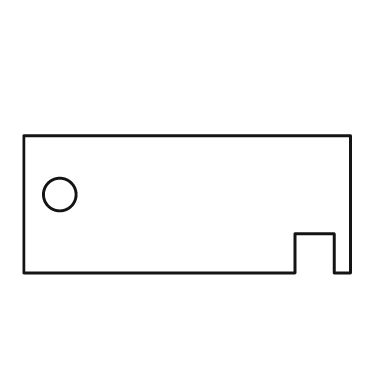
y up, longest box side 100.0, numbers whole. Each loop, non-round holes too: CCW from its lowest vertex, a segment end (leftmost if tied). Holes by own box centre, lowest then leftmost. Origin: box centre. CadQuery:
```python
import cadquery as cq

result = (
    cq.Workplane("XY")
    .moveTo(-50.0, -21.0)
    .lineTo(33.0, -21.0)
    .lineTo(33.0, -9.0)
    .lineTo(45.0, -9.0)
    .lineTo(45.0, -21.0)
    .lineTo(50.0, -21.0)
    .lineTo(50.0, 21.0)
    .lineTo(-50.0, 21.0)
    .close()
    .moveTo(-39.0, 3.0)
    .circle(5.0)
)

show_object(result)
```